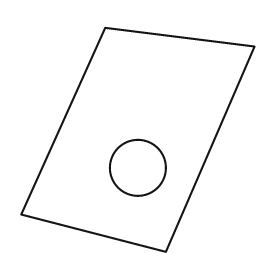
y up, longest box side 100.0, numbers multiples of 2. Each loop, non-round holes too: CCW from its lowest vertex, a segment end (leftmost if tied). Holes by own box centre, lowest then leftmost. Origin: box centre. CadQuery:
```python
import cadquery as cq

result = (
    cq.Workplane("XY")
    .moveTo(12.0, -48.0)
    .lineTo(50.0, 40.0)
    .lineTo(-14.0, 48.0)
    .lineTo(-50.0, -32.0)
    .close()
    .moveTo(0.0, -12.0)
    .circle(12.0)
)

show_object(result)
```